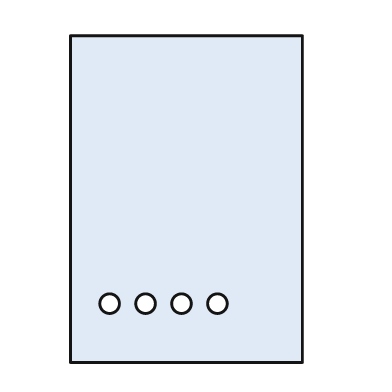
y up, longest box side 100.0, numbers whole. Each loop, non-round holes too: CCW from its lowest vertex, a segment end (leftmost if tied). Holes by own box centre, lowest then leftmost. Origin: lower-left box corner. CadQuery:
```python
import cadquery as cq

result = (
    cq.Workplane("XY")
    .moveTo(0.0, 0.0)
    .lineTo(71.0, 0.0)
    .lineTo(71.0, 100.0)
    .lineTo(0.0, 100.0)
    .close()
    .moveTo(12.0, 18.0)
    .circle(3.0)
    .moveTo(23.0, 18.0)
    .circle(3.0)
    .moveTo(34.0, 18.0)
    .circle(3.0)
    .moveTo(45.0, 18.0)
    .circle(3.0)
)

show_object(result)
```